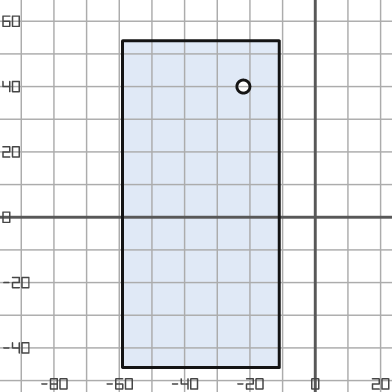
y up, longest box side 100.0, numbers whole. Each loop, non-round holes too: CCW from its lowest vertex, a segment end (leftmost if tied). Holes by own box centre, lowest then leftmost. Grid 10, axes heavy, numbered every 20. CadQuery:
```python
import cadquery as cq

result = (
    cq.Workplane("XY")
    .moveTo(-59.0, -46.0)
    .lineTo(-11.0, -46.0)
    .lineTo(-11.0, 54.0)
    .lineTo(-59.0, 54.0)
    .close()
    .moveTo(-22.0, 40.0)
    .circle(2.0)
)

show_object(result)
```